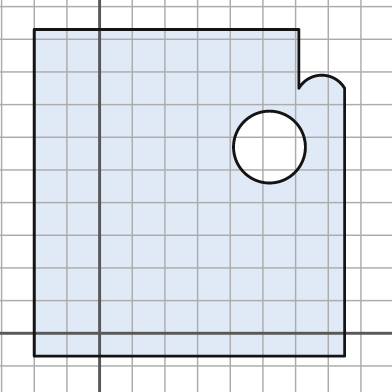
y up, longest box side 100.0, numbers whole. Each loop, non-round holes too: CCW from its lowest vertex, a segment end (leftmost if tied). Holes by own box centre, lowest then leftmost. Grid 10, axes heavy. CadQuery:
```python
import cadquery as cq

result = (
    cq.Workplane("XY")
    .moveTo(-20.0, -7.0)
    .lineTo(75.0, -7.0)
    .lineTo(75.0, 75.0)
    .threePointArc((68.0, 79.0), (61.0, 75.0))
    .lineTo(61.0, 93.0)
    .lineTo(-20.0, 93.0)
    .close()
    .moveTo(52.0, 57.0)
    .circle(11.0)
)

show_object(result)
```